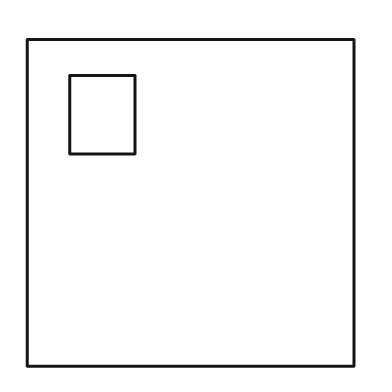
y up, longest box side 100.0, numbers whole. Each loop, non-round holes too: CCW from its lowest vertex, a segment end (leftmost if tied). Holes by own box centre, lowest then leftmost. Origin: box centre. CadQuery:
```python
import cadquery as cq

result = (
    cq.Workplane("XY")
    .moveTo(-50.0, -50.0)
    .lineTo(50.0, -50.0)
    .lineTo(50.0, 50.0)
    .lineTo(-50.0, 50.0)
    .close()
    .moveTo(-37.0, 15.0)
    .lineTo(-17.0, 15.0)
    .lineTo(-17.0, 39.0)
    .lineTo(-37.0, 39.0)
    .close()
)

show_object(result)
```